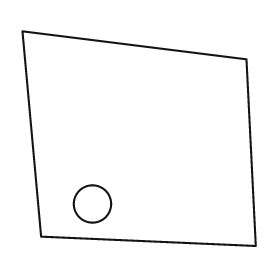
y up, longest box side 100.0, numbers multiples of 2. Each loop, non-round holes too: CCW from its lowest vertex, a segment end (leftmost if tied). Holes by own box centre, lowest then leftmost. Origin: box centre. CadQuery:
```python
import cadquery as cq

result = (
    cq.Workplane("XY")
    .moveTo(50.0, -46.0)
    .lineTo(46.0, 34.0)
    .lineTo(-50.0, 46.0)
    .lineTo(-42.0, -42.0)
    .close()
    .moveTo(-20.0, -28.0)
    .circle(8.0)
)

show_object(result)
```